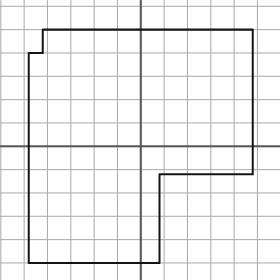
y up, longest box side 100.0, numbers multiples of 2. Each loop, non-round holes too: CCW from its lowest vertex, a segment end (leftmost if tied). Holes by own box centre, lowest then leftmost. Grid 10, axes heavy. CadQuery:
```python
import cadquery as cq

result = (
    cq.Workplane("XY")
    .moveTo(-48.0, -50.0)
    .lineTo(8.0, -50.0)
    .lineTo(8.0, -12.0)
    .lineTo(48.0, -12.0)
    .lineTo(48.0, 50.0)
    .lineTo(-42.0, 50.0)
    .lineTo(-42.0, 40.0)
    .lineTo(-48.0, 40.0)
    .close()
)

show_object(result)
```